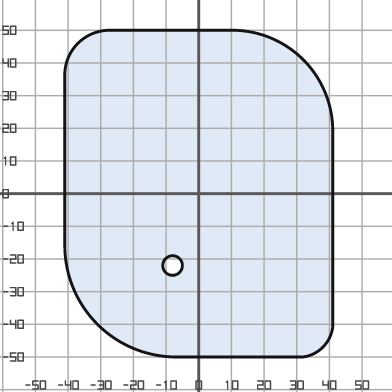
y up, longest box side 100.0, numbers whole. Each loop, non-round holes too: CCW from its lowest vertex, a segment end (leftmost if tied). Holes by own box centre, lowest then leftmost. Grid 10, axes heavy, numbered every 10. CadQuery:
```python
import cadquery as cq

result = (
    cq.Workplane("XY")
    .moveTo(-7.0, -50.0)
    .lineTo(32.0, -50.0)
    .threePointArc((38.0, -47.0), (41.0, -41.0))
    .lineTo(41.0, 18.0)
    .threePointArc((32.0, 41.0), (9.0, 50.0))
    .lineTo(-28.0, 50.0)
    .threePointArc((-37.0, 46.0), (-41.0, 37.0))
    .lineTo(-41.0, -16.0)
    .threePointArc((-31.0, -40.0), (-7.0, -50.0))
    .close()
    .moveTo(-8.0, -22.0)
    .circle(3.0)
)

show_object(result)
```